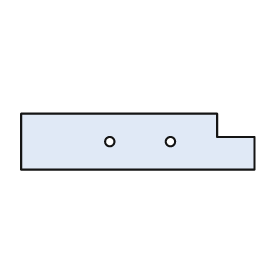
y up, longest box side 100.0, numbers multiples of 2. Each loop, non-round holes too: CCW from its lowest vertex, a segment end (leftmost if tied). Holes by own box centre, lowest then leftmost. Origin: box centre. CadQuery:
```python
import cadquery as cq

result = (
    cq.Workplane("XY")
    .moveTo(-50.0, -12.0)
    .lineTo(50.0, -12.0)
    .lineTo(50.0, 2.0)
    .lineTo(34.0, 2.0)
    .lineTo(34.0, 12.0)
    .lineTo(-50.0, 12.0)
    .close()
    .moveTo(-12.0, 0.0)
    .circle(2.0)
    .moveTo(14.0, 0.0)
    .circle(2.0)
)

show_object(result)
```